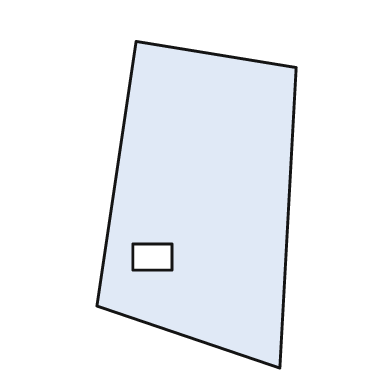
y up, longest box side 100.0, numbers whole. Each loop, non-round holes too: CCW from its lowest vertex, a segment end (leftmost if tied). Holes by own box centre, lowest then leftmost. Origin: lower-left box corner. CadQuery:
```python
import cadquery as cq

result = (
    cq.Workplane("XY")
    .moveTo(56.0, 0.0)
    .lineTo(61.0, 92.0)
    .lineTo(12.0, 100.0)
    .lineTo(0.0, 19.0)
    .close()
    .moveTo(11.0, 30.0)
    .lineTo(23.0, 30.0)
    .lineTo(23.0, 38.0)
    .lineTo(11.0, 38.0)
    .close()
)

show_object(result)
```